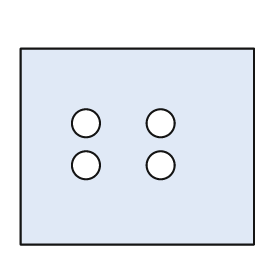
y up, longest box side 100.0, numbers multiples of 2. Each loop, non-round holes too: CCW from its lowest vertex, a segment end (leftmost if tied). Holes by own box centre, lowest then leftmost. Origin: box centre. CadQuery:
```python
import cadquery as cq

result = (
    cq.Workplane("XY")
    .moveTo(-50.0, -42.0)
    .lineTo(50.0, -42.0)
    .lineTo(50.0, 42.0)
    .lineTo(-50.0, 42.0)
    .close()
    .moveTo(-22.0, -8.0)
    .circle(6.0)
    .moveTo(10.0, -8.0)
    .circle(6.0)
    .moveTo(-22.0, 10.0)
    .circle(6.0)
    .moveTo(10.0, 10.0)
    .circle(6.0)
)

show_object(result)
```